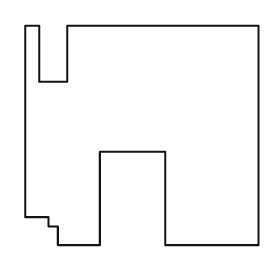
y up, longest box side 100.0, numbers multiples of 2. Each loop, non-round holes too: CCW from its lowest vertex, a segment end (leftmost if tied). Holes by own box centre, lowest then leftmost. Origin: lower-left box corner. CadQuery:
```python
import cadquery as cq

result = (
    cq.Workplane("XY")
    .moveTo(14.0, 0.0)
    .lineTo(32.0, 0.0)
    .lineTo(32.0, 40.0)
    .lineTo(60.0, 40.0)
    .lineTo(60.0, 0.0)
    .lineTo(100.0, 0.0)
    .lineTo(100.0, 94.0)
    .lineTo(18.0, 94.0)
    .lineTo(18.0, 70.0)
    .lineTo(6.0, 70.0)
    .lineTo(6.0, 94.0)
    .lineTo(0.0, 94.0)
    .lineTo(0.0, 12.0)
    .lineTo(10.0, 12.0)
    .lineTo(10.0, 8.0)
    .lineTo(14.0, 8.0)
    .close()
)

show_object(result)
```